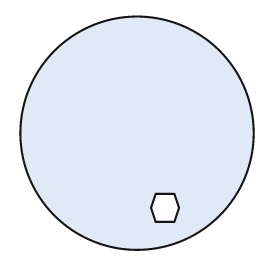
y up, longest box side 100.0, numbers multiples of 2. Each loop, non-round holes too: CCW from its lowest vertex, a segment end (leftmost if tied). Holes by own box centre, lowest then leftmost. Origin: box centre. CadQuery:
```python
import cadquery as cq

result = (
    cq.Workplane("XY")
    .moveTo(0.0, 0.0)
    .circle(50.0)
    .moveTo(8.0, -38.0)
    .lineTo(16.0, -38.0)
    .lineTo(18.0, -32.0)
    .lineTo(16.0, -26.0)
    .lineTo(8.0, -26.0)
    .lineTo(6.0, -32.0)
    .close()
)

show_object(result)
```